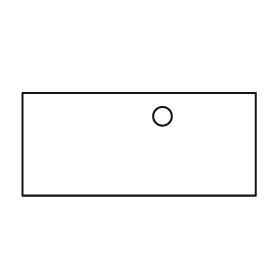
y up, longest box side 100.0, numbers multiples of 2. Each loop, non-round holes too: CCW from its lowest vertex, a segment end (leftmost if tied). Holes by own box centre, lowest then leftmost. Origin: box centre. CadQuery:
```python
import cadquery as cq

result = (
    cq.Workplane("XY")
    .moveTo(-50.0, -22.0)
    .lineTo(50.0, -22.0)
    .lineTo(50.0, 22.0)
    .lineTo(-50.0, 22.0)
    .close()
    .moveTo(10.0, 12.0)
    .circle(4.0)
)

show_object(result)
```